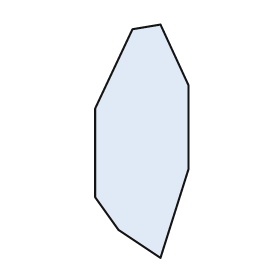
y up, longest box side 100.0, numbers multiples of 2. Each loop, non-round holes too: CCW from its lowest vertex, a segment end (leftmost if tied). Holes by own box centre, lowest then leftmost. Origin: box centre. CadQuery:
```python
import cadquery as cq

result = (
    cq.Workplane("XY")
    .moveTo(8.0, -50.0)
    .lineTo(20.0, -12.0)
    .lineTo(20.0, 24.0)
    .lineTo(8.0, 50.0)
    .lineTo(-4.0, 48.0)
    .lineTo(-20.0, 14.0)
    .lineTo(-20.0, -24.0)
    .lineTo(-10.0, -38.0)
    .close()
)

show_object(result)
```